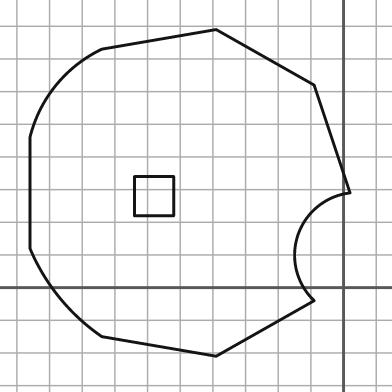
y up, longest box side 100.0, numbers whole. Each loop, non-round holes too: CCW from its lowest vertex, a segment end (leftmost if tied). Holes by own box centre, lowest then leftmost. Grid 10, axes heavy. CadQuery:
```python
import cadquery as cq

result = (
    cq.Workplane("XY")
    .moveTo(-39.0, -21.0)
    .lineTo(-9.0, -4.0)
    .threePointArc((-14.0, 16.0), (2.0, 29.0))
    .lineTo(-9.0, 62.0)
    .lineTo(-39.0, 79.0)
    .lineTo(-74.0, 73.0)
    .threePointArc((-88.0, 62.0), (-96.0, 46.0))
    .lineTo(-96.0, 12.0)
    .threePointArc((-87.0, -3.0), (-74.0, -15.0))
    .close()
    .moveTo(-64.0, 22.0)
    .lineTo(-52.0, 22.0)
    .lineTo(-52.0, 34.0)
    .lineTo(-64.0, 34.0)
    .close()
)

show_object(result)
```